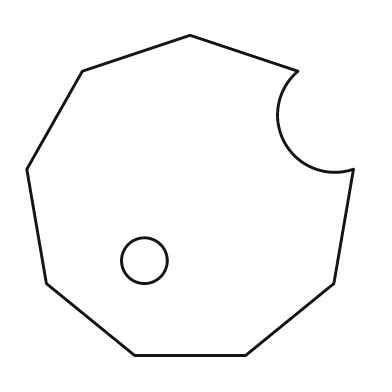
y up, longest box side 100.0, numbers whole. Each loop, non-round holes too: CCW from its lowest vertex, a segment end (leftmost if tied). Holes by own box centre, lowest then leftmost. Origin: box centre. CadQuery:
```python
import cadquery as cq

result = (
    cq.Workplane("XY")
    .moveTo(-17.0, -49.0)
    .lineTo(17.0, -49.0)
    .lineTo(44.0, -27.0)
    .lineTo(50.0, 8.0)
    .threePointArc((29.0, 16.0), (33.0, 38.0))
    .lineTo(0.0, 49.0)
    .lineTo(-33.0, 38.0)
    .lineTo(-50.0, 8.0)
    .lineTo(-44.0, -27.0)
    .close()
    .moveTo(-14.0, -20.0)
    .circle(7.0)
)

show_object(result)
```